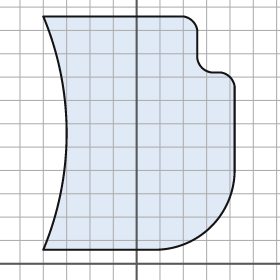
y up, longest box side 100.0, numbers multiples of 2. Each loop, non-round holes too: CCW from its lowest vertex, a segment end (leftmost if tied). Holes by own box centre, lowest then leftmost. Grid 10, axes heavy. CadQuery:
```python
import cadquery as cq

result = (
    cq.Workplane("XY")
    .moveTo(-40.0, 6.0)
    .lineTo(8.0, 6.0)
    .threePointArc((32.0, 16.0), (42.0, 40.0))
    .lineTo(42.0, 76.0)
    .threePointArc((40.0, 80.0), (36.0, 82.0))
    .lineTo(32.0, 82.0)
    .threePointArc((28.0, 84.0), (26.0, 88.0))
    .lineTo(26.0, 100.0)
    .threePointArc((24.0, 104.0), (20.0, 106.0))
    .lineTo(-40.0, 106.0)
    .threePointArc((-30.0, 56.0), (-40.0, 6.0))
    .close()
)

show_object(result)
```